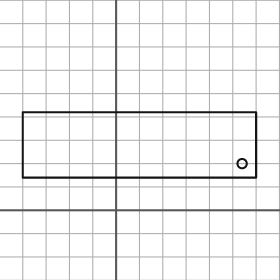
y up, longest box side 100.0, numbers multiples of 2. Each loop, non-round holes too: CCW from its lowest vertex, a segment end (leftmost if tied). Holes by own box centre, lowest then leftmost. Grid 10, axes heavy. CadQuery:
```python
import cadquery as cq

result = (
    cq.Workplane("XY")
    .moveTo(-40.0, 14.0)
    .lineTo(60.0, 14.0)
    .lineTo(60.0, 42.0)
    .lineTo(-40.0, 42.0)
    .close()
    .moveTo(54.0, 20.0)
    .circle(2.0)
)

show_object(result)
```